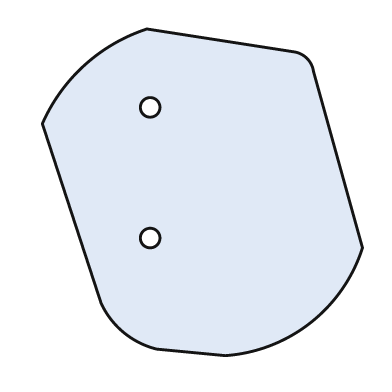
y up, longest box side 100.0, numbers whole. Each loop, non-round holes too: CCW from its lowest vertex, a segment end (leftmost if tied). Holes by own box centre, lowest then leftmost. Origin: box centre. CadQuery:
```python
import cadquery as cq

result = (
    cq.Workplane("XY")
    .moveTo(7.0, -50.0)
    .threePointArc((33.0, -40.0), (49.0, -17.0))
    .lineTo(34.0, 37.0)
    .threePointArc((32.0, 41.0), (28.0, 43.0))
    .lineTo(-17.0, 50.0)
    .threePointArc((-36.0, 39.0), (-49.0, 21.0))
    .lineTo(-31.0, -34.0)
    .threePointArc((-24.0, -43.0), (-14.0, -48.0))
    .close()
    .moveTo(-16.0, -14.0)
    .circle(3.0)
    .moveTo(-16.0, 26.0)
    .circle(3.0)
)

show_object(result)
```